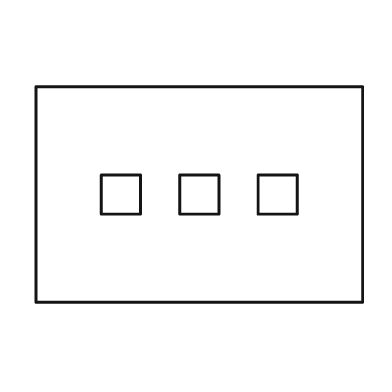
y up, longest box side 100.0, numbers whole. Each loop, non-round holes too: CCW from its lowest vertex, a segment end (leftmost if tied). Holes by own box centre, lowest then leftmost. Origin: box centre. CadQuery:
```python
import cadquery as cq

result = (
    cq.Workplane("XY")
    .moveTo(-50.0, -33.0)
    .lineTo(50.0, -33.0)
    .lineTo(50.0, 33.0)
    .lineTo(-50.0, 33.0)
    .close()
    .moveTo(-30.0, -6.0)
    .lineTo(-18.0, -6.0)
    .lineTo(-18.0, 6.0)
    .lineTo(-30.0, 6.0)
    .close()
    .moveTo(-6.0, -6.0)
    .lineTo(6.0, -6.0)
    .lineTo(6.0, 6.0)
    .lineTo(-6.0, 6.0)
    .close()
    .moveTo(18.0, -6.0)
    .lineTo(30.0, -6.0)
    .lineTo(30.0, 6.0)
    .lineTo(18.0, 6.0)
    .close()
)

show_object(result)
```